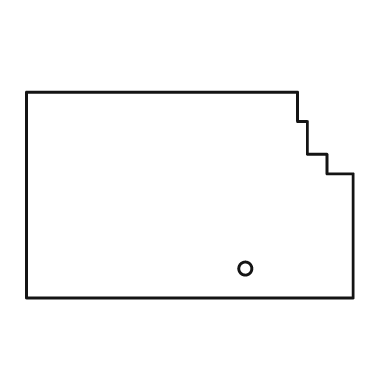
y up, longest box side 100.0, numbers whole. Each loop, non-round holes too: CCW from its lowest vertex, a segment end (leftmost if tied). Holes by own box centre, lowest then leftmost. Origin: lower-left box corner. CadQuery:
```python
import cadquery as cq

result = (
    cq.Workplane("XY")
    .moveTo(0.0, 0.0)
    .lineTo(100.0, 0.0)
    .lineTo(100.0, 38.0)
    .lineTo(92.0, 38.0)
    .lineTo(92.0, 44.0)
    .lineTo(86.0, 44.0)
    .lineTo(86.0, 54.0)
    .lineTo(83.0, 54.0)
    .lineTo(83.0, 63.0)
    .lineTo(0.0, 63.0)
    .close()
    .moveTo(67.0, 9.0)
    .circle(2.0)
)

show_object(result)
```